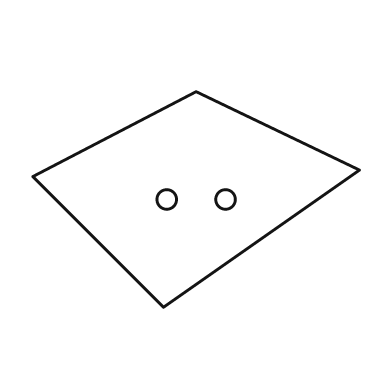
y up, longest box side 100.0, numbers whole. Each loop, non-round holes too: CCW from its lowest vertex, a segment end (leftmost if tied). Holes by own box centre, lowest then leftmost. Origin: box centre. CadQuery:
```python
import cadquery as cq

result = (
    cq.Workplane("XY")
    .moveTo(-10.0, -33.0)
    .lineTo(50.0, 9.0)
    .lineTo(0.0, 33.0)
    .lineTo(-50.0, 7.0)
    .close()
    .moveTo(-9.0, 0.0)
    .circle(3.0)
    .moveTo(9.0, 0.0)
    .circle(3.0)
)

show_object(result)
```